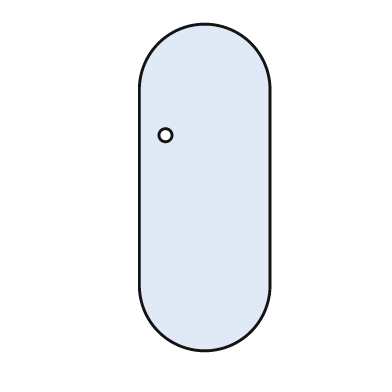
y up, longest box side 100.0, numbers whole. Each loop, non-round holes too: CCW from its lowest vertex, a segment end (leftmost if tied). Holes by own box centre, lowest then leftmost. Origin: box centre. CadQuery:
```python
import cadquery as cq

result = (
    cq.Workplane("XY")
    .moveTo(-20.0, -30.0)
    .threePointArc((0.0, -50.0), (20.0, -30.0))
    .lineTo(20.0, 30.0)
    .threePointArc((0.0, 50.0), (-20.0, 30.0))
    .close()
    .moveTo(-12.0, 16.0)
    .circle(2.0)
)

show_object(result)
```